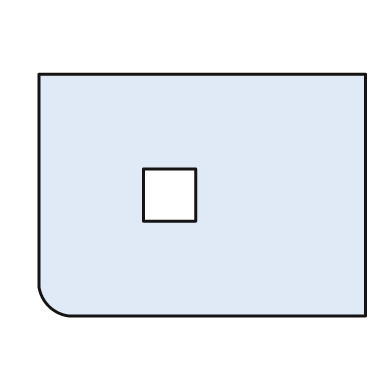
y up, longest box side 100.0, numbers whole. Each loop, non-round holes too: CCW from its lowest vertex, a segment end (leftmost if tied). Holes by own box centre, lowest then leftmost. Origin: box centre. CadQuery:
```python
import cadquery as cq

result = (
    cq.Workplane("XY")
    .moveTo(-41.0, -37.0)
    .lineTo(50.0, -37.0)
    .lineTo(50.0, 37.0)
    .lineTo(-50.0, 37.0)
    .lineTo(-50.0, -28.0)
    .threePointArc((-47.0, -34.0), (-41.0, -37.0))
    .close()
    .moveTo(-18.0, -8.0)
    .lineTo(-2.0, -8.0)
    .lineTo(-2.0, 8.0)
    .lineTo(-18.0, 8.0)
    .close()
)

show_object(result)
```